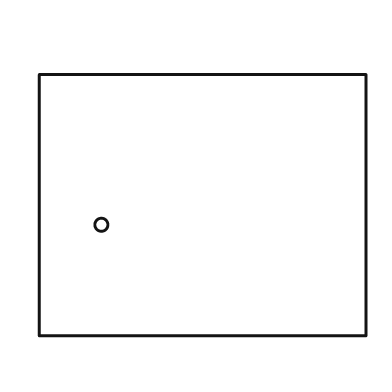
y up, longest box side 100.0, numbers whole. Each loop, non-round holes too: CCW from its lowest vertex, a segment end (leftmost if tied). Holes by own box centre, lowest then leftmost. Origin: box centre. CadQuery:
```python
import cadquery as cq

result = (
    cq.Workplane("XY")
    .moveTo(-50.0, -40.0)
    .lineTo(50.0, -40.0)
    .lineTo(50.0, 40.0)
    .lineTo(-50.0, 40.0)
    .close()
    .moveTo(-31.0, -6.0)
    .circle(2.0)
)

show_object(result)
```